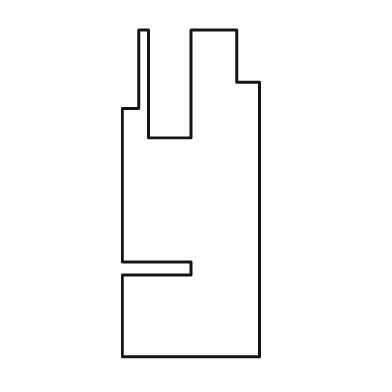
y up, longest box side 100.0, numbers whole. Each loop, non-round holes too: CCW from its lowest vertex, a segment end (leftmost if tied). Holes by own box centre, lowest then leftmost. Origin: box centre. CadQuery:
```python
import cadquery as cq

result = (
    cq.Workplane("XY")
    .moveTo(-21.0, -50.0)
    .lineTo(21.0, -50.0)
    .lineTo(21.0, 34.0)
    .lineTo(14.0, 34.0)
    .lineTo(14.0, 50.0)
    .lineTo(0.0, 50.0)
    .lineTo(0.0, 17.0)
    .lineTo(-13.0, 17.0)
    .lineTo(-13.0, 50.0)
    .lineTo(-16.0, 50.0)
    .lineTo(-16.0, 26.0)
    .lineTo(-21.0, 26.0)
    .lineTo(-21.0, -21.0)
    .lineTo(0.0, -21.0)
    .lineTo(0.0, -25.0)
    .lineTo(-21.0, -25.0)
    .close()
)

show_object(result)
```